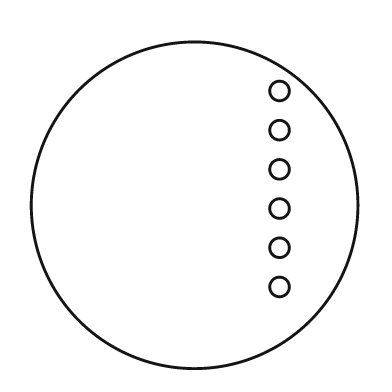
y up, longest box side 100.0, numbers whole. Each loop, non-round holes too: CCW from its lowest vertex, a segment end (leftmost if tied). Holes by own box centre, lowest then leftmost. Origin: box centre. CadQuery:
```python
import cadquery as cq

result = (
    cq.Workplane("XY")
    .moveTo(0.0, 0.0)
    .circle(50.0)
    .moveTo(26.0, -25.0)
    .circle(3.0)
    .moveTo(26.0, -13.0)
    .circle(3.0)
    .moveTo(26.0, -1.0)
    .circle(3.0)
    .moveTo(26.0, 11.0)
    .circle(3.0)
    .moveTo(26.0, 23.0)
    .circle(3.0)
    .moveTo(26.0, 35.0)
    .circle(3.0)
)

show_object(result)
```